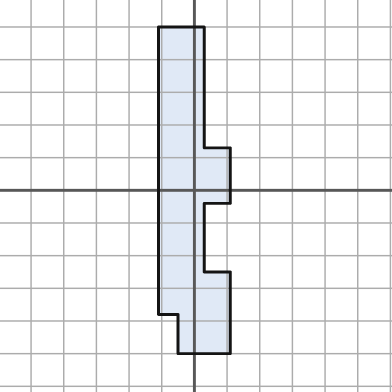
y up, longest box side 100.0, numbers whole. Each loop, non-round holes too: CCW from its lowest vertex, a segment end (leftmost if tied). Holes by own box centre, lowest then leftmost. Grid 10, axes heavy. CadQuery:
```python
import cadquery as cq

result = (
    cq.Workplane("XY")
    .moveTo(-5.0, -50.0)
    .lineTo(11.0, -50.0)
    .lineTo(11.0, -25.0)
    .lineTo(3.0, -25.0)
    .lineTo(3.0, -4.0)
    .lineTo(11.0, -4.0)
    .lineTo(11.0, 13.0)
    .lineTo(3.0, 13.0)
    .lineTo(3.0, 50.0)
    .lineTo(-11.0, 50.0)
    .lineTo(-11.0, -38.0)
    .lineTo(-5.0, -38.0)
    .close()
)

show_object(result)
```